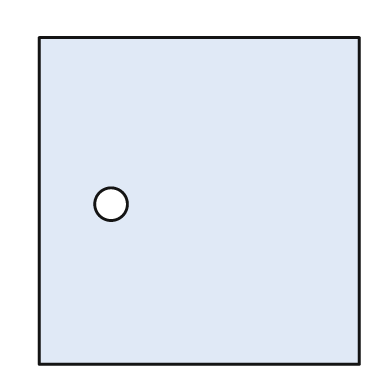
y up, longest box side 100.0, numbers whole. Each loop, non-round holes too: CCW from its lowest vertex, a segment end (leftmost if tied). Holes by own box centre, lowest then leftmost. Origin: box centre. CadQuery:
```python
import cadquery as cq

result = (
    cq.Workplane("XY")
    .moveTo(-49.0, -50.0)
    .lineTo(49.0, -50.0)
    .lineTo(49.0, 50.0)
    .lineTo(-49.0, 50.0)
    .close()
    .moveTo(-27.0, -1.0)
    .circle(5.0)
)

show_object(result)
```